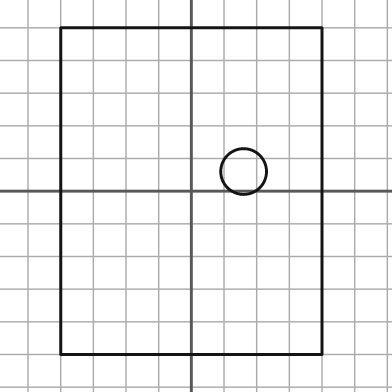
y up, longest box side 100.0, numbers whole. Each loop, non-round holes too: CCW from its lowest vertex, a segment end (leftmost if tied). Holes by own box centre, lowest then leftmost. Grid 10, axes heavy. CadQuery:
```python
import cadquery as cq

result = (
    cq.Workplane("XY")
    .moveTo(-40.0, -50.0)
    .lineTo(40.0, -50.0)
    .lineTo(40.0, 50.0)
    .lineTo(-40.0, 50.0)
    .close()
    .moveTo(16.0, 6.0)
    .circle(7.0)
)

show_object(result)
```